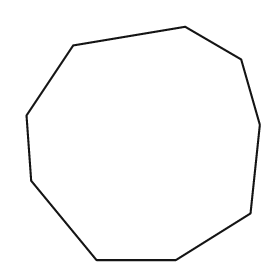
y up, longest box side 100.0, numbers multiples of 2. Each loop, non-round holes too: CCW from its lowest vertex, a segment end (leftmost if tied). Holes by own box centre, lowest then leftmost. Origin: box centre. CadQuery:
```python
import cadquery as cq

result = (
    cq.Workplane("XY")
    .moveTo(-20.0, -50.0)
    .lineTo(14.0, -50.0)
    .lineTo(46.0, -30.0)
    .lineTo(50.0, 8.0)
    .lineTo(42.0, 36.0)
    .lineTo(18.0, 50.0)
    .lineTo(-30.0, 42.0)
    .lineTo(-50.0, 12.0)
    .lineTo(-48.0, -16.0)
    .close()
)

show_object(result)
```